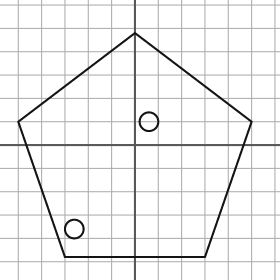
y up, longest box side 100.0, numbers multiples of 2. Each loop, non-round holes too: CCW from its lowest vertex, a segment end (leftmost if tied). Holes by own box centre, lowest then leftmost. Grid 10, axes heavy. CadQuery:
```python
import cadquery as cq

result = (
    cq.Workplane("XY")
    .moveTo(-30.0, -48.0)
    .lineTo(30.0, -48.0)
    .lineTo(50.0, 10.0)
    .lineTo(0.0, 48.0)
    .lineTo(-50.0, 10.0)
    .close()
    .moveTo(-26.0, -36.0)
    .circle(4.0)
    .moveTo(6.0, 10.0)
    .circle(4.0)
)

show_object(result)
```